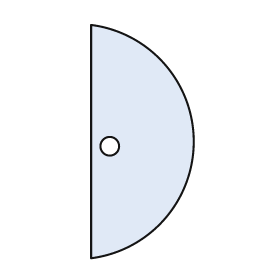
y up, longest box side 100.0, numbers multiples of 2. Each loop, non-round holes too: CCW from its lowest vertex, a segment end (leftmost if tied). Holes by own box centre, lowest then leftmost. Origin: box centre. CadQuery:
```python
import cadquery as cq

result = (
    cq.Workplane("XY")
    .moveTo(-22.0, -50.0)
    .threePointArc((22.0, 0.0), (-22.0, 50.0))
    .close()
    .moveTo(-14.0, -2.0)
    .circle(4.0)
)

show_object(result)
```